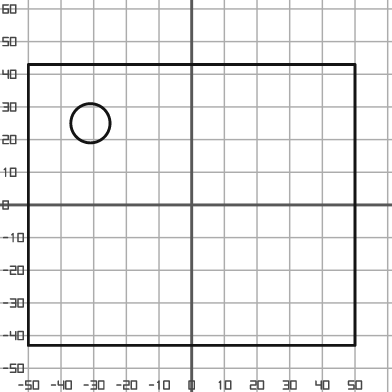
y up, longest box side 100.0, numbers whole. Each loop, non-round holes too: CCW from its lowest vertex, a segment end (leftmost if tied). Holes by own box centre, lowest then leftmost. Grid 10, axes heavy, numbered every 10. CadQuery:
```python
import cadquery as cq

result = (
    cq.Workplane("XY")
    .moveTo(-50.0, -43.0)
    .lineTo(50.0, -43.0)
    .lineTo(50.0, 43.0)
    .lineTo(-50.0, 43.0)
    .close()
    .moveTo(-31.0, 25.0)
    .circle(6.0)
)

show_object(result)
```